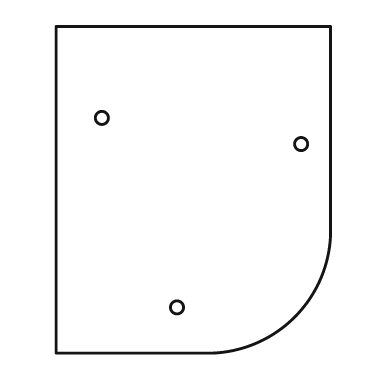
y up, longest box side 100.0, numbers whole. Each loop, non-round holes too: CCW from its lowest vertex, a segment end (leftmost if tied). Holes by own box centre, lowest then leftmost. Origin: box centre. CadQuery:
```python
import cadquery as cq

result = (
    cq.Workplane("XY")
    .moveTo(-42.0, -50.0)
    .lineTo(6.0, -50.0)
    .threePointArc((31.0, -39.0), (42.0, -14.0))
    .lineTo(42.0, 50.0)
    .lineTo(-42.0, 50.0)
    .close()
    .moveTo(-5.0, -36.0)
    .circle(2.0)
    .moveTo(33.0, 14.0)
    .circle(2.0)
    .moveTo(-28.0, 22.0)
    .circle(2.0)
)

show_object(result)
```